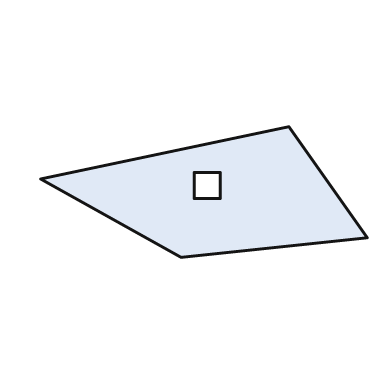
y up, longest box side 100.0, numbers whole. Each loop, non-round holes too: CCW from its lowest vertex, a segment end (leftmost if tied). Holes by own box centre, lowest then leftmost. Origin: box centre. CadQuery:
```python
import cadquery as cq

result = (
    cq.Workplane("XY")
    .moveTo(-7.0, -20.0)
    .lineTo(50.0, -14.0)
    .lineTo(26.0, 20.0)
    .lineTo(-50.0, 4.0)
    .close()
    .moveTo(-3.0, -2.0)
    .lineTo(5.0, -2.0)
    .lineTo(5.0, 6.0)
    .lineTo(-3.0, 6.0)
    .close()
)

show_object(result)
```